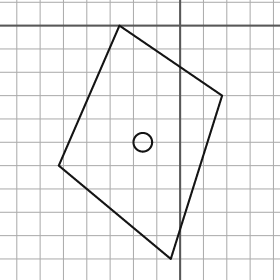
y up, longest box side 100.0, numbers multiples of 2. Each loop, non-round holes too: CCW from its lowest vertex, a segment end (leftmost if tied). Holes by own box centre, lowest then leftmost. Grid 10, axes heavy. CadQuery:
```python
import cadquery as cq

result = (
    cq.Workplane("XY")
    .moveTo(-4.0, -100.0)
    .lineTo(18.0, -30.0)
    .lineTo(-26.0, 0.0)
    .lineTo(-52.0, -60.0)
    .close()
    .moveTo(-16.0, -50.0)
    .circle(4.0)
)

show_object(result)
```